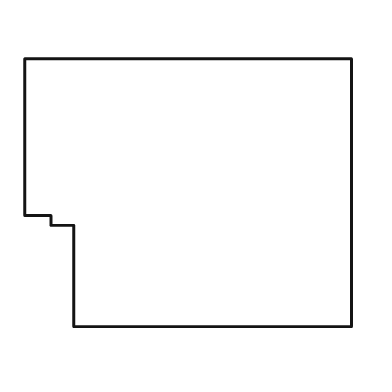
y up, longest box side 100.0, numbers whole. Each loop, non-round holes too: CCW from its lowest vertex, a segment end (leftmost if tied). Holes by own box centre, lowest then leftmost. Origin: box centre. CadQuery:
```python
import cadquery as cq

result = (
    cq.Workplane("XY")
    .moveTo(-35.0, -41.0)
    .lineTo(50.0, -41.0)
    .lineTo(50.0, 41.0)
    .lineTo(-50.0, 41.0)
    .lineTo(-50.0, -7.0)
    .lineTo(-42.0, -7.0)
    .lineTo(-42.0, -10.0)
    .lineTo(-35.0, -10.0)
    .close()
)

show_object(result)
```